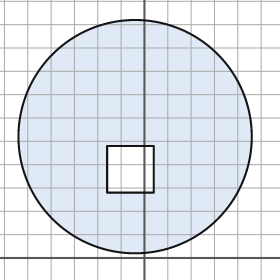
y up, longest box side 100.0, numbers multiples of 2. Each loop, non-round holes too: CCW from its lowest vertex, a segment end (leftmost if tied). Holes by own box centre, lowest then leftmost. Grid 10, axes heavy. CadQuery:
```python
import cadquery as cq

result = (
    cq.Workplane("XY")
    .moveTo(-4.0, 52.0)
    .circle(50.0)
    .moveTo(-16.0, 28.0)
    .lineTo(4.0, 28.0)
    .lineTo(4.0, 48.0)
    .lineTo(-16.0, 48.0)
    .close()
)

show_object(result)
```